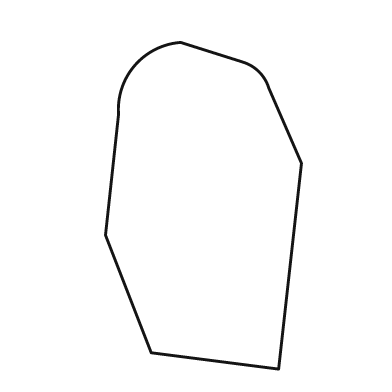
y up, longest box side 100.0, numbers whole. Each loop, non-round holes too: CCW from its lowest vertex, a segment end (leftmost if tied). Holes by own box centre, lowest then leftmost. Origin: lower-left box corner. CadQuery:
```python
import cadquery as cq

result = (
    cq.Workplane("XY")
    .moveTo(53.0, 0.0)
    .lineTo(60.0, 63.0)
    .lineTo(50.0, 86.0)
    .threePointArc((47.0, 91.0), (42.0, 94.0))
    .lineTo(23.0, 100.0)
    .threePointArc((9.0, 93.0), (4.0, 78.0))
    .lineTo(0.0, 41.0)
    .lineTo(14.0, 5.0)
    .close()
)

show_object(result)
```